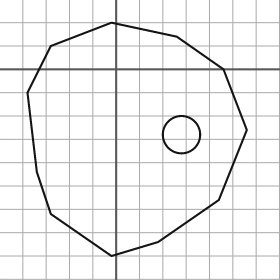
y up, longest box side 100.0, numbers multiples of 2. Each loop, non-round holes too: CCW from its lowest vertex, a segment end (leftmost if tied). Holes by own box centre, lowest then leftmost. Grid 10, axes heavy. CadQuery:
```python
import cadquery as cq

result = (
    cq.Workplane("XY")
    .moveTo(-2.0, -80.0)
    .lineTo(18.0, -74.0)
    .lineTo(44.0, -56.0)
    .lineTo(56.0, -26.0)
    .lineTo(46.0, 0.0)
    .lineTo(26.0, 14.0)
    .lineTo(-2.0, 20.0)
    .lineTo(-28.0, 10.0)
    .lineTo(-38.0, -10.0)
    .lineTo(-34.0, -44.0)
    .lineTo(-28.0, -62.0)
    .close()
    .moveTo(28.0, -28.0)
    .circle(8.0)
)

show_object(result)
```